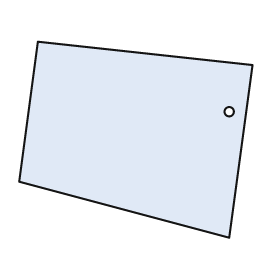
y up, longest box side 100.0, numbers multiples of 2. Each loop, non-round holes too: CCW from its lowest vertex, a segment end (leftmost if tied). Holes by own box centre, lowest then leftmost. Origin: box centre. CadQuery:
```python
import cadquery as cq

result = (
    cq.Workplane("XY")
    .moveTo(40.0, -42.0)
    .lineTo(50.0, 32.0)
    .lineTo(-42.0, 42.0)
    .lineTo(-50.0, -18.0)
    .close()
    .moveTo(40.0, 12.0)
    .circle(2.0)
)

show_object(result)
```